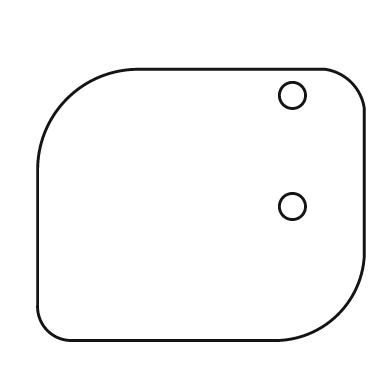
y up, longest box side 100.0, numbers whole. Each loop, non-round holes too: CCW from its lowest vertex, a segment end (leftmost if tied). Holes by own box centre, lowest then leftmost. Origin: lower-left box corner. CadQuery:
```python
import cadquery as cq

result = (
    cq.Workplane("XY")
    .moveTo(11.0, 0.0)
    .lineTo(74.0, 0.0)
    .threePointArc((92.0, 8.0), (100.0, 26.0))
    .lineTo(100.0, 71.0)
    .threePointArc((96.0, 79.0), (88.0, 83.0))
    .lineTo(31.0, 83.0)
    .threePointArc((9.0, 74.0), (0.0, 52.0))
    .lineTo(0.0, 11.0)
    .threePointArc((3.0, 3.0), (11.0, 0.0))
    .close()
    .moveTo(78.0, 41.0)
    .circle(4.0)
    .moveTo(78.0, 75.0)
    .circle(4.0)
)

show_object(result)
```